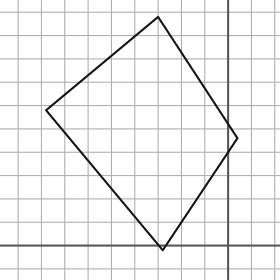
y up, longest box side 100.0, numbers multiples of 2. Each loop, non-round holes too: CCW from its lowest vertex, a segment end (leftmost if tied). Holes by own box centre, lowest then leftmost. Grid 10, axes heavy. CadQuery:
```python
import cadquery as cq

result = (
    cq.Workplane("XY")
    .moveTo(-28.0, -2.0)
    .lineTo(4.0, 46.0)
    .lineTo(-30.0, 98.0)
    .lineTo(-78.0, 58.0)
    .close()
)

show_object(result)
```